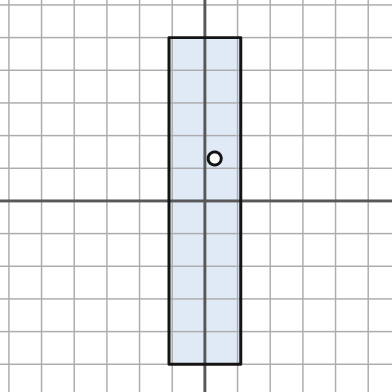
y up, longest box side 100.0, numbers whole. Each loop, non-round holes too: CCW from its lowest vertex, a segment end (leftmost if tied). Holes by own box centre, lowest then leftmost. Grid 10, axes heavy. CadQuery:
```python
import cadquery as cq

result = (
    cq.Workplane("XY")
    .moveTo(-11.0, -50.0)
    .lineTo(11.0, -50.0)
    .lineTo(11.0, 50.0)
    .lineTo(-11.0, 50.0)
    .close()
    .moveTo(3.0, 13.0)
    .circle(2.0)
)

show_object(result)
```